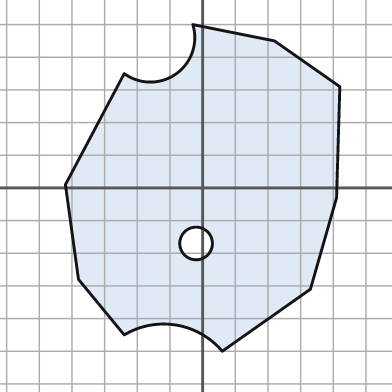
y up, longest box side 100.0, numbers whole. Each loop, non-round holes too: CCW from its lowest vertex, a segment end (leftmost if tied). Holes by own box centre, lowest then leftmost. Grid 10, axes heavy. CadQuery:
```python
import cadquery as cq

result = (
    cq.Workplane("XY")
    .moveTo(6.0, -50.0)
    .lineTo(33.0, -31.0)
    .lineTo(41.0, -3.0)
    .lineTo(42.0, 31.0)
    .lineTo(22.0, 45.0)
    .lineTo(-3.0, 50.0)
    .threePointArc((-8.0, 35.0), (-24.0, 35.0))
    .lineTo(-42.0, 1.0)
    .lineTo(-38.0, -28.0)
    .lineTo(-24.0, -45.0)
    .threePointArc((-8.0, -42.0), (6.0, -50.0))
    .close()
    .moveTo(-2.0, -17.0)
    .circle(5.0)
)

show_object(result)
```